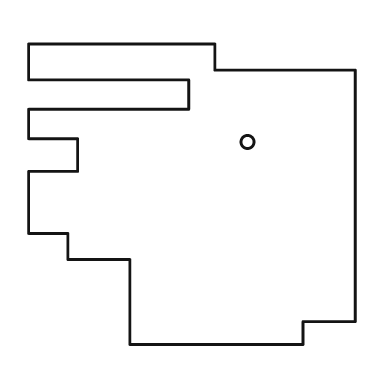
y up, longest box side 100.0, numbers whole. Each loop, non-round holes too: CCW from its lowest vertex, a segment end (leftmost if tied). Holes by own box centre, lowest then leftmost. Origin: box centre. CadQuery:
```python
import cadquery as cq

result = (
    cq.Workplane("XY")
    .moveTo(-19.0, -46.0)
    .lineTo(34.0, -46.0)
    .lineTo(34.0, -39.0)
    .lineTo(50.0, -39.0)
    .lineTo(50.0, 38.0)
    .lineTo(7.0, 38.0)
    .lineTo(7.0, 46.0)
    .lineTo(-50.0, 46.0)
    .lineTo(-50.0, 35.0)
    .lineTo(-1.0, 35.0)
    .lineTo(-1.0, 26.0)
    .lineTo(-50.0, 26.0)
    .lineTo(-50.0, 17.0)
    .lineTo(-35.0, 17.0)
    .lineTo(-35.0, 7.0)
    .lineTo(-50.0, 7.0)
    .lineTo(-50.0, -12.0)
    .lineTo(-38.0, -12.0)
    .lineTo(-38.0, -20.0)
    .lineTo(-19.0, -20.0)
    .close()
    .moveTo(17.0, 16.0)
    .circle(2.0)
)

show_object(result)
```